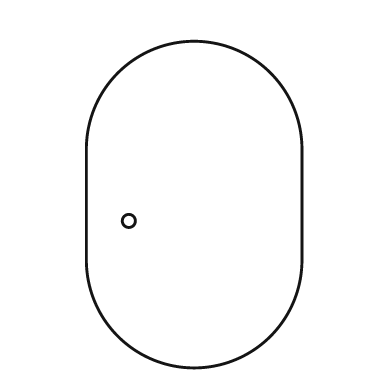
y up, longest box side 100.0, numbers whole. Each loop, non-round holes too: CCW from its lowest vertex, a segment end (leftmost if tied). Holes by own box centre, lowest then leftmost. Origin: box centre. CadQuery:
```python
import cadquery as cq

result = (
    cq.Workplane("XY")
    .moveTo(-33.0, -17.0)
    .threePointArc((0.0, -50.0), (33.0, -17.0))
    .lineTo(33.0, 17.0)
    .threePointArc((0.0, 50.0), (-33.0, 17.0))
    .close()
    .moveTo(-20.0, -5.0)
    .circle(2.0)
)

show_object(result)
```